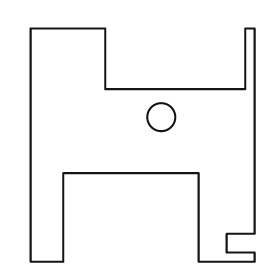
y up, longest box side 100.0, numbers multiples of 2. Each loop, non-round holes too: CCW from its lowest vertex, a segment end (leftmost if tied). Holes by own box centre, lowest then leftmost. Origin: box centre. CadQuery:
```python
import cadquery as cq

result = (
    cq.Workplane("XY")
    .moveTo(-48.0, -50.0)
    .lineTo(-34.0, -50.0)
    .lineTo(-34.0, -12.0)
    .lineTo(24.0, -12.0)
    .lineTo(24.0, -50.0)
    .lineTo(48.0, -50.0)
    .lineTo(48.0, -46.0)
    .lineTo(36.0, -46.0)
    .lineTo(36.0, -38.0)
    .lineTo(48.0, -38.0)
    .lineTo(48.0, 50.0)
    .lineTo(44.0, 50.0)
    .lineTo(44.0, 24.0)
    .lineTo(-16.0, 24.0)
    .lineTo(-16.0, 50.0)
    .lineTo(-48.0, 50.0)
    .close()
    .moveTo(8.0, 12.0)
    .circle(6.0)
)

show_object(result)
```